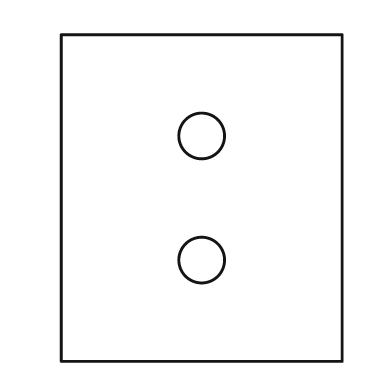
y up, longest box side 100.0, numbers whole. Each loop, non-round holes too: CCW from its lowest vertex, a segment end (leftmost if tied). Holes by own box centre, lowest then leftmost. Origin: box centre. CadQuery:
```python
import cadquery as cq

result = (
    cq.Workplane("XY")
    .moveTo(-43.0, -50.0)
    .lineTo(43.0, -50.0)
    .lineTo(43.0, 50.0)
    .lineTo(-43.0, 50.0)
    .close()
    .moveTo(0.0, -19.0)
    .circle(7.0)
    .moveTo(0.0, 19.0)
    .circle(7.0)
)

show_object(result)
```